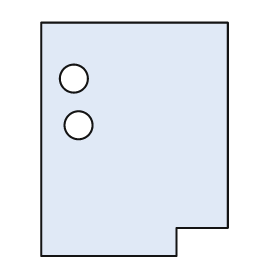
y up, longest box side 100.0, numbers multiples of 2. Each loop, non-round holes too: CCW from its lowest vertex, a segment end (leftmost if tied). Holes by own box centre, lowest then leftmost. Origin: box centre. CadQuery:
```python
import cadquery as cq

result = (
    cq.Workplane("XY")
    .moveTo(-40.0, -50.0)
    .lineTo(18.0, -50.0)
    .lineTo(18.0, -38.0)
    .lineTo(40.0, -38.0)
    .lineTo(40.0, 50.0)
    .lineTo(-40.0, 50.0)
    .close()
    .moveTo(-24.0, 6.0)
    .circle(6.0)
    .moveTo(-26.0, 26.0)
    .circle(6.0)
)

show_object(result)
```